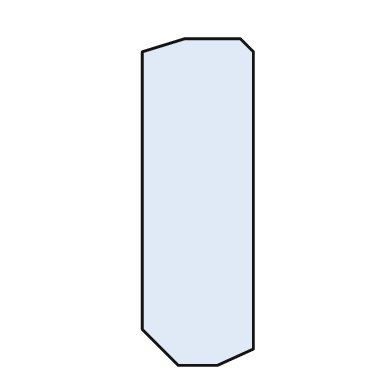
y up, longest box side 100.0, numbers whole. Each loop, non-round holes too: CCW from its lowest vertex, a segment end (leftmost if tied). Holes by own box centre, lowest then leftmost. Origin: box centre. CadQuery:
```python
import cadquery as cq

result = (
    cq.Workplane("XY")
    .moveTo(-6.0, -50.0)
    .lineTo(6.0, -50.0)
    .lineTo(17.0, -45.0)
    .lineTo(17.0, 46.0)
    .lineTo(13.0, 50.0)
    .lineTo(-4.0, 50.0)
    .lineTo(-17.0, 46.0)
    .lineTo(-17.0, -39.0)
    .close()
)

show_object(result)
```